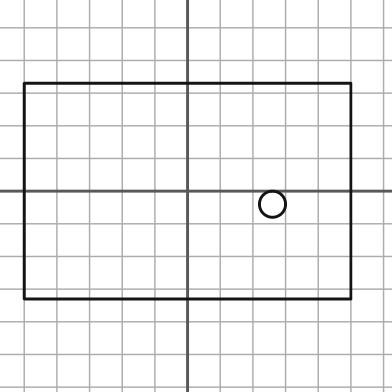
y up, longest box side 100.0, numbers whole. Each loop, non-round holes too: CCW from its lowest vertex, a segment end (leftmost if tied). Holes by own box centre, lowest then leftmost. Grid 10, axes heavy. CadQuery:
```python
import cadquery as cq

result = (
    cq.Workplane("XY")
    .moveTo(-50.0, -33.0)
    .lineTo(50.0, -33.0)
    .lineTo(50.0, 33.0)
    .lineTo(-50.0, 33.0)
    .close()
    .moveTo(26.0, -4.0)
    .circle(4.0)
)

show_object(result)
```